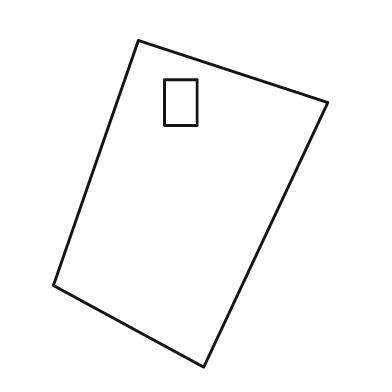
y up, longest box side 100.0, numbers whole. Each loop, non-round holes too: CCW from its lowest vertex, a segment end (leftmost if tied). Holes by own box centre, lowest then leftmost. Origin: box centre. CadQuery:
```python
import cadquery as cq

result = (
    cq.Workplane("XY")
    .moveTo(4.0, -50.0)
    .lineTo(42.0, 31.0)
    .lineTo(-16.0, 50.0)
    .lineTo(-42.0, -25.0)
    .close()
    .moveTo(-8.0, 24.0)
    .lineTo(2.0, 24.0)
    .lineTo(2.0, 38.0)
    .lineTo(-8.0, 38.0)
    .close()
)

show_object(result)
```